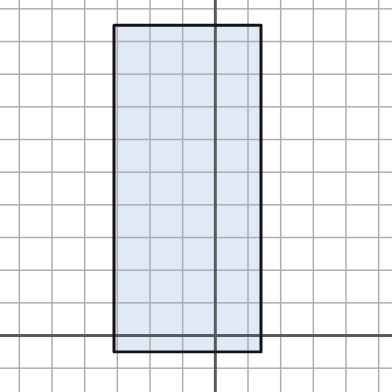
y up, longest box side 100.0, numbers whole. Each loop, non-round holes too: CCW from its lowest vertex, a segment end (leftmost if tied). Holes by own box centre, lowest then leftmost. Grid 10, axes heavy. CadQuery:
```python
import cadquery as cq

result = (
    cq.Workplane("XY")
    .moveTo(-31.0, -5.0)
    .lineTo(14.0, -5.0)
    .lineTo(14.0, 95.0)
    .lineTo(-31.0, 95.0)
    .close()
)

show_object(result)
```